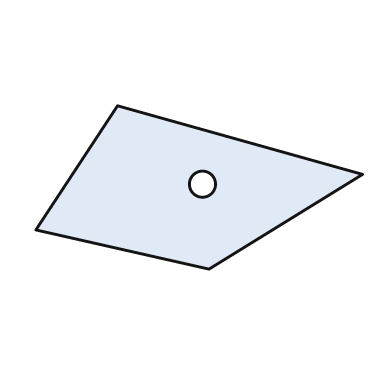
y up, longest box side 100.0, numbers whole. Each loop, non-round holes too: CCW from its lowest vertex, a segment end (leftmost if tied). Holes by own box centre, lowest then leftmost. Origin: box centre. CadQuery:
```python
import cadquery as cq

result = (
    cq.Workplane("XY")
    .moveTo(3.0, -25.0)
    .lineTo(50.0, 4.0)
    .lineTo(-25.0, 25.0)
    .lineTo(-50.0, -13.0)
    .close()
    .moveTo(1.0, 1.0)
    .circle(4.0)
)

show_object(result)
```